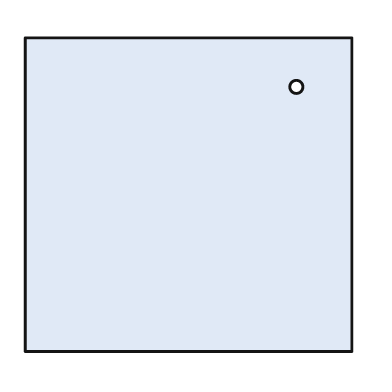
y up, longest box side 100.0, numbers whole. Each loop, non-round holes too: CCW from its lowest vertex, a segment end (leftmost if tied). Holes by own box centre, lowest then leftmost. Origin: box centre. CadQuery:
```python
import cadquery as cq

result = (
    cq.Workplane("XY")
    .moveTo(-50.0, -48.0)
    .lineTo(50.0, -48.0)
    .lineTo(50.0, 48.0)
    .lineTo(-50.0, 48.0)
    .close()
    .moveTo(33.0, 33.0)
    .circle(2.0)
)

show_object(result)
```